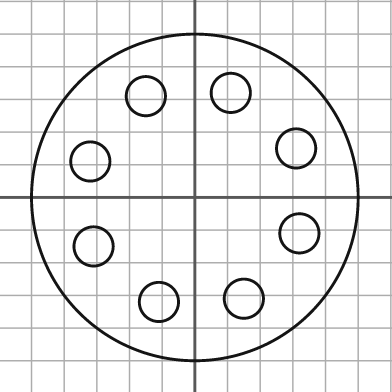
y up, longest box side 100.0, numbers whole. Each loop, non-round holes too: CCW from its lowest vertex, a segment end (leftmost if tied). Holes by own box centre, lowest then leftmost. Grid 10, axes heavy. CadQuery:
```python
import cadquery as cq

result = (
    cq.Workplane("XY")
    .moveTo(0.0, 0.0)
    .circle(50.0)
    .moveTo(-11.0, -32.0)
    .circle(6.0)
    .moveTo(15.0, -31.0)
    .circle(6.0)
    .moveTo(-31.0, -15.0)
    .circle(6.0)
    .moveTo(32.0, -11.0)
    .circle(6.0)
    .moveTo(-32.0, 11.0)
    .circle(6.0)
    .moveTo(31.0, 15.0)
    .circle(6.0)
    .moveTo(-15.0, 31.0)
    .circle(6.0)
    .moveTo(11.0, 32.0)
    .circle(6.0)
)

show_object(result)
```